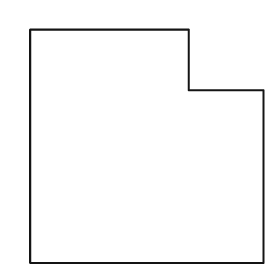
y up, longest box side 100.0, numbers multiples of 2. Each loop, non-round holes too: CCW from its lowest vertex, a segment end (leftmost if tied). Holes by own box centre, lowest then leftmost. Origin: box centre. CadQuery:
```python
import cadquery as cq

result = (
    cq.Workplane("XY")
    .moveTo(-50.0, -50.0)
    .lineTo(50.0, -50.0)
    .lineTo(50.0, 24.0)
    .lineTo(18.0, 24.0)
    .lineTo(18.0, 50.0)
    .lineTo(-50.0, 50.0)
    .close()
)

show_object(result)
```